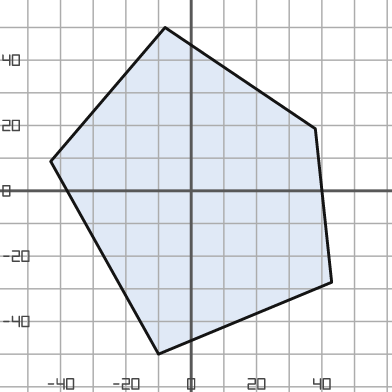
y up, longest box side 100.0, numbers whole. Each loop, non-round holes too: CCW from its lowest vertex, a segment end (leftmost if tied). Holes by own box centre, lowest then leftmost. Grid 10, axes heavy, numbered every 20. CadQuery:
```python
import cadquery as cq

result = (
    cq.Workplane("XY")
    .moveTo(-10.0, -50.0)
    .lineTo(43.0, -28.0)
    .lineTo(38.0, 19.0)
    .lineTo(-8.0, 50.0)
    .lineTo(-43.0, 9.0)
    .close()
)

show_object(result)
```